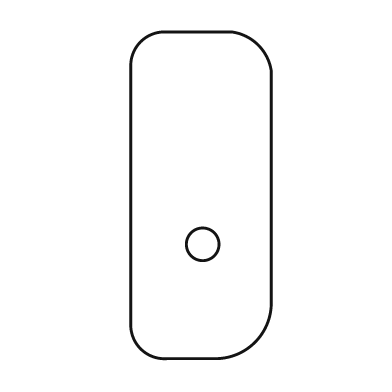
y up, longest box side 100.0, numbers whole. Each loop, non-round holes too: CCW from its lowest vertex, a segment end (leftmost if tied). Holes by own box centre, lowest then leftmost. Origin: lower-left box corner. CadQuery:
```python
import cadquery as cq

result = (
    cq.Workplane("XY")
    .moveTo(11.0, 0.0)
    .lineTo(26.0, 0.0)
    .threePointArc((38.0, 5.0), (43.0, 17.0))
    .lineTo(43.0, 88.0)
    .threePointArc((39.0, 96.0), (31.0, 100.0))
    .lineTo(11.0, 100.0)
    .threePointArc((3.0, 97.0), (0.0, 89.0))
    .lineTo(0.0, 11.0)
    .threePointArc((3.0, 3.0), (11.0, 0.0))
    .close()
    .moveTo(22.0, 35.0)
    .circle(5.0)
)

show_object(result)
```